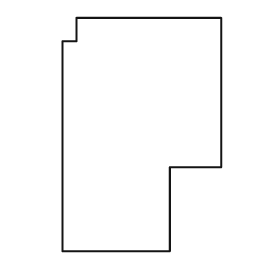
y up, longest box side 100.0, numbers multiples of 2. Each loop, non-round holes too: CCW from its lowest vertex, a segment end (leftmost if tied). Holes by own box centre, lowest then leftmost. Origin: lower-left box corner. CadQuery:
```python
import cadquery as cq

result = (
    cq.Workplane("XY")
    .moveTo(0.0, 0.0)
    .lineTo(46.0, 0.0)
    .lineTo(46.0, 36.0)
    .lineTo(68.0, 36.0)
    .lineTo(68.0, 100.0)
    .lineTo(6.0, 100.0)
    .lineTo(6.0, 90.0)
    .lineTo(0.0, 90.0)
    .close()
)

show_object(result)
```